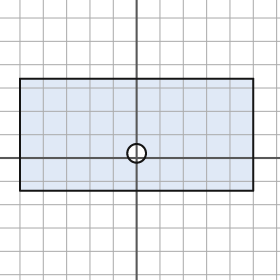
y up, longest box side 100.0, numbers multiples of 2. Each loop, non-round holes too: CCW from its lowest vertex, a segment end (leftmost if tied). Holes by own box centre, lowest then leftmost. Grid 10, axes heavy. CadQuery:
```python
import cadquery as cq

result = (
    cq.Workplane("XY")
    .moveTo(-50.0, -14.0)
    .lineTo(50.0, -14.0)
    .lineTo(50.0, 34.0)
    .lineTo(-50.0, 34.0)
    .close()
    .moveTo(0.0, 2.0)
    .circle(4.0)
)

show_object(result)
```